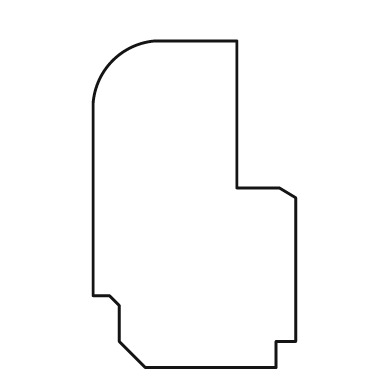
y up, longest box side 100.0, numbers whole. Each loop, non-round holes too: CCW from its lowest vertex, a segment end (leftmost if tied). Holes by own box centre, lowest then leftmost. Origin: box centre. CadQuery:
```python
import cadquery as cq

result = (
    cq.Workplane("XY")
    .moveTo(-15.0, -50.0)
    .lineTo(25.0, -50.0)
    .lineTo(25.0, -42.0)
    .lineTo(31.0, -42.0)
    .lineTo(31.0, 2.0)
    .lineTo(26.0, 5.0)
    .lineTo(13.0, 5.0)
    .lineTo(13.0, 50.0)
    .lineTo(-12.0, 50.0)
    .threePointArc((-25.0, 44.0), (-31.0, 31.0))
    .lineTo(-31.0, -28.0)
    .lineTo(-26.0, -28.0)
    .lineTo(-23.0, -31.0)
    .lineTo(-23.0, -42.0)
    .close()
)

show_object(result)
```